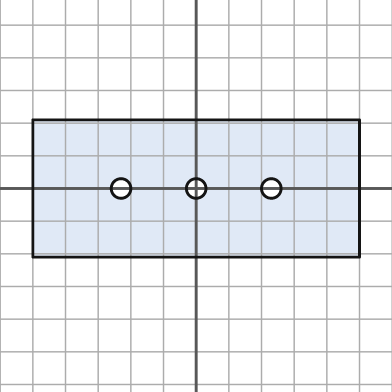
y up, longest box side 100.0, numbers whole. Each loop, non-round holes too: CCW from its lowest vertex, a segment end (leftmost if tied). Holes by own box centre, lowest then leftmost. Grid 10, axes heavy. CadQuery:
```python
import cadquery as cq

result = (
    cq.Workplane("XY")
    .moveTo(-50.0, -21.0)
    .lineTo(50.0, -21.0)
    .lineTo(50.0, 21.0)
    .lineTo(-50.0, 21.0)
    .close()
    .moveTo(-23.0, 0.0)
    .circle(3.0)
    .moveTo(0.0, 0.0)
    .circle(3.0)
    .moveTo(23.0, 0.0)
    .circle(3.0)
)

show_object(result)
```